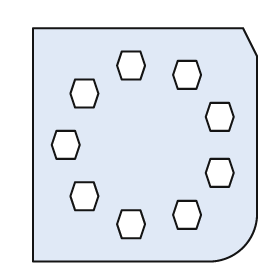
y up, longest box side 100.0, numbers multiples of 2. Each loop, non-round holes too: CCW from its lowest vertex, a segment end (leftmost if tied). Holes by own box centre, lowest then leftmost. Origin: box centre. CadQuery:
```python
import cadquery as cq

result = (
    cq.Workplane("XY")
    .moveTo(-48.0, -50.0)
    .lineTo(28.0, -50.0)
    .threePointArc((42.0, -44.0), (48.0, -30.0))
    .lineTo(48.0, 38.0)
    .lineTo(42.0, 50.0)
    .lineTo(-48.0, 50.0)
    .close()
    .moveTo(-10.0, -40.0)
    .lineTo(-2.0, -40.0)
    .lineTo(0.0, -34.0)
    .lineTo(-2.0, -28.0)
    .lineTo(-10.0, -28.0)
    .lineTo(-12.0, -34.0)
    .close()
    .moveTo(14.0, -36.0)
    .lineTo(22.0, -36.0)
    .lineTo(24.0, -30.0)
    .lineTo(22.0, -24.0)
    .lineTo(14.0, -24.0)
    .lineTo(12.0, -30.0)
    .close()
    .moveTo(-30.0, -28.0)
    .lineTo(-22.0, -28.0)
    .lineTo(-20.0, -22.0)
    .lineTo(-22.0, -16.0)
    .lineTo(-30.0, -16.0)
    .lineTo(-32.0, -22.0)
    .close()
    .moveTo(28.0, -18.0)
    .lineTo(36.0, -18.0)
    .lineTo(38.0, -12.0)
    .lineTo(36.0, -6.0)
    .lineTo(28.0, -6.0)
    .lineTo(26.0, -12.0)
    .close()
    .moveTo(-38.0, -6.0)
    .lineTo(-30.0, -6.0)
    .lineTo(-28.0, 0.0)
    .lineTo(-30.0, 6.0)
    .lineTo(-38.0, 6.0)
    .lineTo(-40.0, 0.0)
    .close()
    .moveTo(28.0, 6.0)
    .lineTo(36.0, 6.0)
    .lineTo(38.0, 12.0)
    .lineTo(36.0, 18.0)
    .lineTo(28.0, 18.0)
    .lineTo(26.0, 12.0)
    .close()
    .moveTo(-30.0, 16.0)
    .lineTo(-22.0, 16.0)
    .lineTo(-20.0, 22.0)
    .lineTo(-22.0, 28.0)
    .lineTo(-30.0, 28.0)
    .lineTo(-32.0, 22.0)
    .close()
    .moveTo(14.0, 24.0)
    .lineTo(22.0, 24.0)
    .lineTo(24.0, 30.0)
    .lineTo(22.0, 36.0)
    .lineTo(14.0, 36.0)
    .lineTo(12.0, 30.0)
    .close()
    .moveTo(-10.0, 28.0)
    .lineTo(-2.0, 28.0)
    .lineTo(0.0, 34.0)
    .lineTo(-2.0, 40.0)
    .lineTo(-10.0, 40.0)
    .lineTo(-12.0, 34.0)
    .close()
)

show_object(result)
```